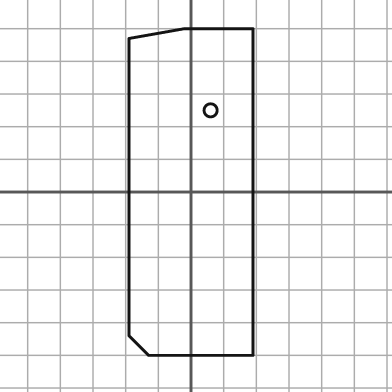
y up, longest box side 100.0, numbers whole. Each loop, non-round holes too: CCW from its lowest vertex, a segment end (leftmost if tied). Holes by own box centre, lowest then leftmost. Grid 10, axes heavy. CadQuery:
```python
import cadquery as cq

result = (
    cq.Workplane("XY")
    .moveTo(-13.0, -50.0)
    .lineTo(19.0, -50.0)
    .lineTo(19.0, 50.0)
    .lineTo(-2.0, 50.0)
    .lineTo(-19.0, 47.0)
    .lineTo(-19.0, -44.0)
    .close()
    .moveTo(6.0, 25.0)
    .circle(2.0)
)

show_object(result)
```